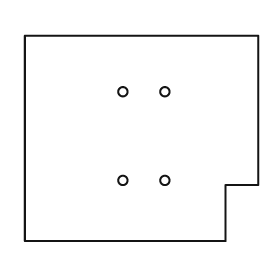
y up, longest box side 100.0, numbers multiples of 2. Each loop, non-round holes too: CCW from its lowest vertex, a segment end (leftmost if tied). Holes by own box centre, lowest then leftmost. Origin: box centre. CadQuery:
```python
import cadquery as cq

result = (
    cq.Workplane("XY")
    .moveTo(-50.0, -44.0)
    .lineTo(36.0, -44.0)
    .lineTo(36.0, -20.0)
    .lineTo(50.0, -20.0)
    .lineTo(50.0, 44.0)
    .lineTo(-50.0, 44.0)
    .close()
    .moveTo(-8.0, -18.0)
    .circle(2.0)
    .moveTo(10.0, -18.0)
    .circle(2.0)
    .moveTo(-8.0, 20.0)
    .circle(2.0)
    .moveTo(10.0, 20.0)
    .circle(2.0)
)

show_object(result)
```